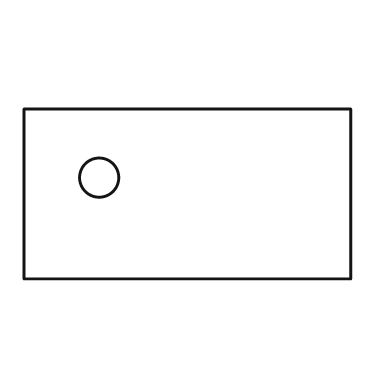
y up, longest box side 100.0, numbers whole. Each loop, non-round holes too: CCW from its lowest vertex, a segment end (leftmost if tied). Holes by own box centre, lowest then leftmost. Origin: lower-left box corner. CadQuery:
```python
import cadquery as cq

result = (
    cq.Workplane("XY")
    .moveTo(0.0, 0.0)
    .lineTo(100.0, 0.0)
    .lineTo(100.0, 52.0)
    .lineTo(0.0, 52.0)
    .close()
    .moveTo(23.0, 31.0)
    .circle(6.0)
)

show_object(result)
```